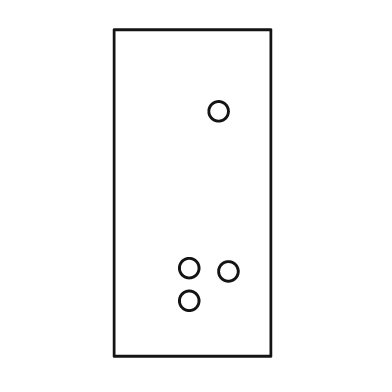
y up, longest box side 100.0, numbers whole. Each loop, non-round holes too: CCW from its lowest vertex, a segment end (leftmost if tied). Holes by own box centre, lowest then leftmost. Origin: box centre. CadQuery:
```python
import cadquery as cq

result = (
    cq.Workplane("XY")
    .moveTo(-24.0, -50.0)
    .lineTo(24.0, -50.0)
    .lineTo(24.0, 50.0)
    .lineTo(-24.0, 50.0)
    .close()
    .moveTo(-1.0, -33.0)
    .circle(3.0)
    .moveTo(11.0, -24.0)
    .circle(3.0)
    .moveTo(-1.0, -23.0)
    .circle(3.0)
    .moveTo(8.0, 25.0)
    .circle(3.0)
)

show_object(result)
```